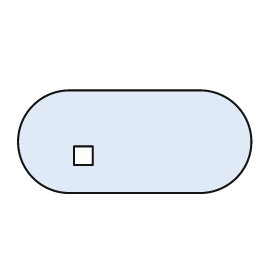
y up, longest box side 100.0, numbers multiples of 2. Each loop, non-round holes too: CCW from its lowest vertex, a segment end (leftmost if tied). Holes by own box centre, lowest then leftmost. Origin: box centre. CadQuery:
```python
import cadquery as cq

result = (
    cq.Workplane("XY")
    .moveTo(-28.0, -22.0)
    .lineTo(28.0, -22.0)
    .threePointArc((50.0, 0.0), (28.0, 22.0))
    .lineTo(-28.0, 22.0)
    .threePointArc((-50.0, 0.0), (-28.0, -22.0))
    .close()
    .moveTo(-26.0, -10.0)
    .lineTo(-18.0, -10.0)
    .lineTo(-18.0, -2.0)
    .lineTo(-26.0, -2.0)
    .close()
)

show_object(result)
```